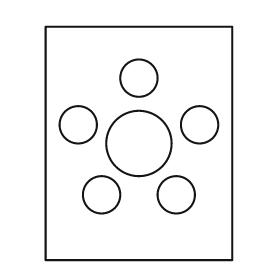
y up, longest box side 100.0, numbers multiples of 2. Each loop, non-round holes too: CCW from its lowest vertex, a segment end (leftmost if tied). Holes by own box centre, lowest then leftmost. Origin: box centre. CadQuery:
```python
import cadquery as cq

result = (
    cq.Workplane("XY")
    .moveTo(-40.0, -50.0)
    .lineTo(40.0, -50.0)
    .lineTo(40.0, 50.0)
    .lineTo(-40.0, 50.0)
    .close()
    .moveTo(-16.0, -22.0)
    .circle(8.0)
    .moveTo(16.0, -22.0)
    .circle(8.0)
    .moveTo(0.0, 0.0)
    .circle(14.0)
    .moveTo(-26.0, 8.0)
    .circle(8.0)
    .moveTo(26.0, 8.0)
    .circle(8.0)
    .moveTo(0.0, 28.0)
    .circle(8.0)
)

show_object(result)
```